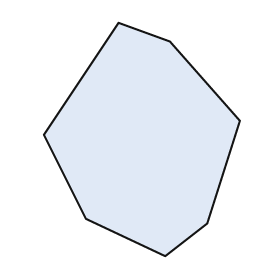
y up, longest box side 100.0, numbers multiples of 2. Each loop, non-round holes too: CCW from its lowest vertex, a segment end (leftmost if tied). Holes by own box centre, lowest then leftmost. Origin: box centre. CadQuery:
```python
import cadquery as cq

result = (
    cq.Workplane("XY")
    .moveTo(10.0, -50.0)
    .lineTo(28.0, -36.0)
    .lineTo(42.0, 8.0)
    .lineTo(12.0, 42.0)
    .lineTo(-10.0, 50.0)
    .lineTo(-42.0, 2.0)
    .lineTo(-24.0, -34.0)
    .close()
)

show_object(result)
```